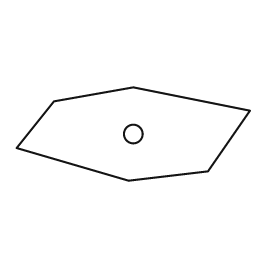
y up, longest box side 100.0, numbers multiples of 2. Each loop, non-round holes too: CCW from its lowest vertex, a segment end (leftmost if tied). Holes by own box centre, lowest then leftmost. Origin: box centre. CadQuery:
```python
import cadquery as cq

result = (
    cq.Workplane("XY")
    .moveTo(-2.0, -20.0)
    .lineTo(32.0, -16.0)
    .lineTo(50.0, 10.0)
    .lineTo(0.0, 20.0)
    .lineTo(-34.0, 14.0)
    .lineTo(-50.0, -6.0)
    .close()
    .moveTo(0.0, 0.0)
    .circle(4.0)
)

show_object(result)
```